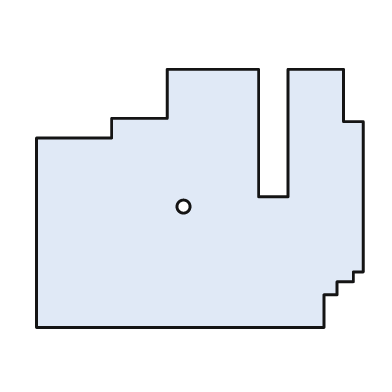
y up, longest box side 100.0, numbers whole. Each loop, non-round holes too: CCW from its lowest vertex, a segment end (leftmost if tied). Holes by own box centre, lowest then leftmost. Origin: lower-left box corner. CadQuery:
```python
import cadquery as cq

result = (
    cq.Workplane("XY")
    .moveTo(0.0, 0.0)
    .lineTo(88.0, 0.0)
    .lineTo(88.0, 10.0)
    .lineTo(92.0, 10.0)
    .lineTo(92.0, 14.0)
    .lineTo(97.0, 14.0)
    .lineTo(97.0, 17.0)
    .lineTo(100.0, 17.0)
    .lineTo(100.0, 63.0)
    .lineTo(94.0, 63.0)
    .lineTo(94.0, 79.0)
    .lineTo(77.0, 79.0)
    .lineTo(77.0, 40.0)
    .lineTo(68.0, 40.0)
    .lineTo(68.0, 79.0)
    .lineTo(40.0, 79.0)
    .lineTo(40.0, 64.0)
    .lineTo(23.0, 64.0)
    .lineTo(23.0, 58.0)
    .lineTo(0.0, 58.0)
    .close()
    .moveTo(45.0, 37.0)
    .circle(2.0)
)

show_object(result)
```